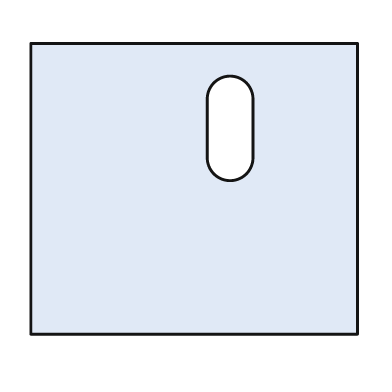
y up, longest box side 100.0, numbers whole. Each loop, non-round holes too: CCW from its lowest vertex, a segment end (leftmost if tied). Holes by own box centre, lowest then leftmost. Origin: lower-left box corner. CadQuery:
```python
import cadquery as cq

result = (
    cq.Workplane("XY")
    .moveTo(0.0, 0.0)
    .lineTo(100.0, 0.0)
    .lineTo(100.0, 89.0)
    .lineTo(0.0, 89.0)
    .close()
    .moveTo(54.0, 54.0)
    .threePointArc((61.0, 47.0), (68.0, 54.0))
    .lineTo(68.0, 72.0)
    .threePointArc((61.0, 79.0), (54.0, 72.0))
    .close()
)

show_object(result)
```